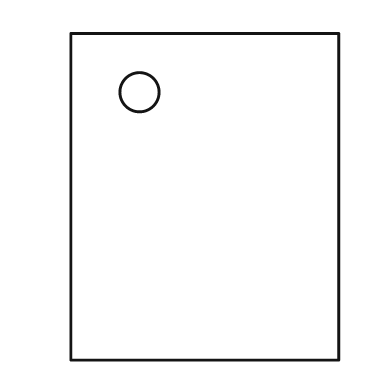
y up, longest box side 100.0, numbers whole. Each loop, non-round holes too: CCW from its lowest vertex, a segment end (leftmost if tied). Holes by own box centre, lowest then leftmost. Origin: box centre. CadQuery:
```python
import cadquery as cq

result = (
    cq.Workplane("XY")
    .moveTo(-41.0, -50.0)
    .lineTo(41.0, -50.0)
    .lineTo(41.0, 50.0)
    .lineTo(-41.0, 50.0)
    .close()
    .moveTo(-20.0, 32.0)
    .circle(6.0)
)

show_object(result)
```